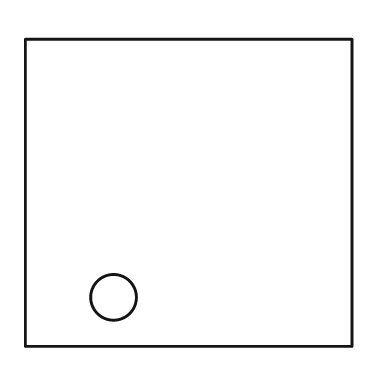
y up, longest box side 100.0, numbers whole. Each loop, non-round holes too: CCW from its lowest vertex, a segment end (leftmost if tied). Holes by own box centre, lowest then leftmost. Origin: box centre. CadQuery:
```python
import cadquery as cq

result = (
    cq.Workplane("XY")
    .moveTo(-50.0, -47.0)
    .lineTo(50.0, -47.0)
    .lineTo(50.0, 47.0)
    .lineTo(-50.0, 47.0)
    .close()
    .moveTo(-23.0, -32.0)
    .circle(7.0)
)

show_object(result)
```